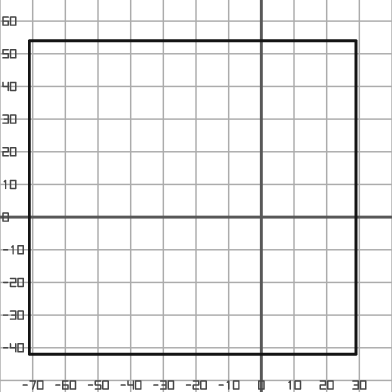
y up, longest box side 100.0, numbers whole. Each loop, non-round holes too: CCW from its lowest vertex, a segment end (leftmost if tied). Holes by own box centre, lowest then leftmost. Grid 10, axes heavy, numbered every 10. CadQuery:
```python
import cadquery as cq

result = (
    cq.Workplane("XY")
    .moveTo(-71.0, -42.0)
    .lineTo(29.0, -42.0)
    .lineTo(29.0, 54.0)
    .lineTo(-71.0, 54.0)
    .close()
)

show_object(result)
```